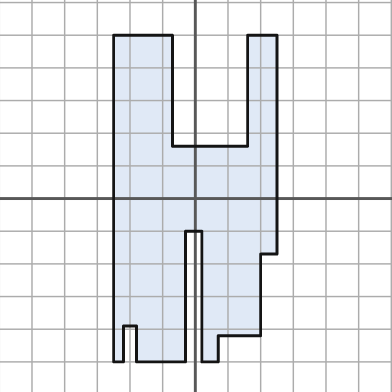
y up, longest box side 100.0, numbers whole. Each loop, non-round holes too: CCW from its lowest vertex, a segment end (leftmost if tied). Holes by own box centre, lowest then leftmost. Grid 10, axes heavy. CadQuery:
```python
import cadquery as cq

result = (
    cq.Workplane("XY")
    .moveTo(-25.0, -50.0)
    .lineTo(-22.0, -50.0)
    .lineTo(-22.0, -39.0)
    .lineTo(-18.0, -39.0)
    .lineTo(-18.0, -50.0)
    .lineTo(-3.0, -50.0)
    .lineTo(-3.0, -10.0)
    .lineTo(2.0, -10.0)
    .lineTo(2.0, -50.0)
    .lineTo(7.0, -50.0)
    .lineTo(7.0, -42.0)
    .lineTo(20.0, -42.0)
    .lineTo(20.0, -17.0)
    .lineTo(25.0, -17.0)
    .lineTo(25.0, 50.0)
    .lineTo(16.0, 50.0)
    .lineTo(16.0, 16.0)
    .lineTo(-7.0, 16.0)
    .lineTo(-7.0, 50.0)
    .lineTo(-25.0, 50.0)
    .close()
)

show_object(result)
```